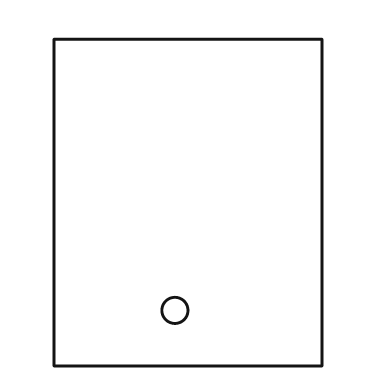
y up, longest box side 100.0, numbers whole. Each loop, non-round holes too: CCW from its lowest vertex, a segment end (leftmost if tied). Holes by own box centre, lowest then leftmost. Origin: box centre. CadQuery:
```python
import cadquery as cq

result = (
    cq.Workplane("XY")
    .moveTo(-41.0, -50.0)
    .lineTo(41.0, -50.0)
    .lineTo(41.0, 50.0)
    .lineTo(-41.0, 50.0)
    .close()
    .moveTo(-4.0, -33.0)
    .circle(4.0)
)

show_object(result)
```